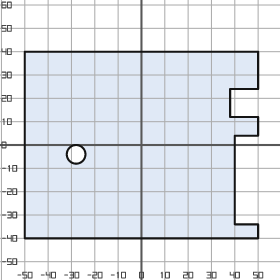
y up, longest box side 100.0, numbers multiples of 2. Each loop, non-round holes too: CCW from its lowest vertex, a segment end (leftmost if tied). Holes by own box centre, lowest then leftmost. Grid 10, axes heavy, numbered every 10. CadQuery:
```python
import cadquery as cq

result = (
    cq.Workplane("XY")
    .moveTo(-50.0, -40.0)
    .lineTo(50.0, -40.0)
    .lineTo(50.0, -34.0)
    .lineTo(40.0, -34.0)
    .lineTo(40.0, 4.0)
    .lineTo(50.0, 4.0)
    .lineTo(50.0, 12.0)
    .lineTo(38.0, 12.0)
    .lineTo(38.0, 24.0)
    .lineTo(50.0, 24.0)
    .lineTo(50.0, 40.0)
    .lineTo(-50.0, 40.0)
    .close()
    .moveTo(-28.0, -4.0)
    .circle(4.0)
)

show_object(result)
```